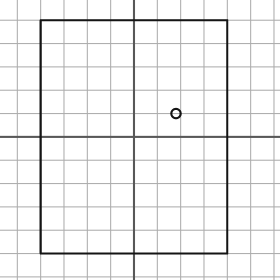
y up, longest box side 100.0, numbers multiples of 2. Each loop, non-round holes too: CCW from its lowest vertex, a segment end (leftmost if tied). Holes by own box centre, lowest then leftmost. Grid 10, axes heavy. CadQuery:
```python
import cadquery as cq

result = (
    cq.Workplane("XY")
    .moveTo(-40.0, -50.0)
    .lineTo(40.0, -50.0)
    .lineTo(40.0, 50.0)
    .lineTo(-40.0, 50.0)
    .close()
    .moveTo(18.0, 10.0)
    .circle(2.0)
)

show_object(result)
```